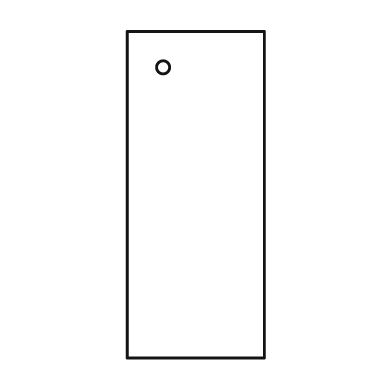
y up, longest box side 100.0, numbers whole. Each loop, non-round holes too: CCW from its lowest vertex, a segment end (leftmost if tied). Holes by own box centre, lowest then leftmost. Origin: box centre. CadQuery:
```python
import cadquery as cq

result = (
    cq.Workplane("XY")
    .moveTo(-21.0, -50.0)
    .lineTo(21.0, -50.0)
    .lineTo(21.0, 50.0)
    .lineTo(-21.0, 50.0)
    .close()
    .moveTo(-10.0, 39.0)
    .circle(2.0)
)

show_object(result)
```